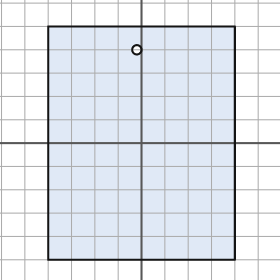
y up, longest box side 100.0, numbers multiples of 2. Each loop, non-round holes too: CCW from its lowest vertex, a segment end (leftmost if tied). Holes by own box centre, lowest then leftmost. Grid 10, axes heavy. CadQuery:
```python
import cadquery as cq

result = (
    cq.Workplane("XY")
    .moveTo(-40.0, -50.0)
    .lineTo(40.0, -50.0)
    .lineTo(40.0, 50.0)
    .lineTo(-40.0, 50.0)
    .close()
    .moveTo(-2.0, 40.0)
    .circle(2.0)
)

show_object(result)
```